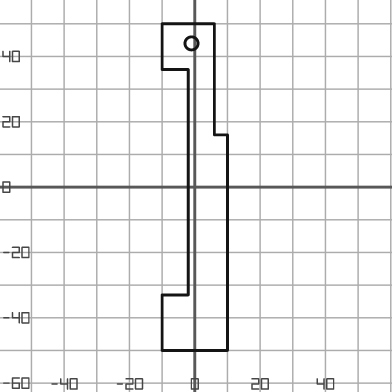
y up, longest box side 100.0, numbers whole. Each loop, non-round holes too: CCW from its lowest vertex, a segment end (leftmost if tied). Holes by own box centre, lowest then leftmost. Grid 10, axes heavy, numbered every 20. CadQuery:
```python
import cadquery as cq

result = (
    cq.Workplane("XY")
    .moveTo(-10.0, -50.0)
    .lineTo(10.0, -50.0)
    .lineTo(10.0, 16.0)
    .lineTo(6.0, 16.0)
    .lineTo(6.0, 50.0)
    .lineTo(-10.0, 50.0)
    .lineTo(-10.0, 36.0)
    .lineTo(-2.0, 36.0)
    .lineTo(-2.0, -33.0)
    .lineTo(-10.0, -33.0)
    .close()
    .moveTo(-1.0, 44.0)
    .circle(2.0)
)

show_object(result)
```